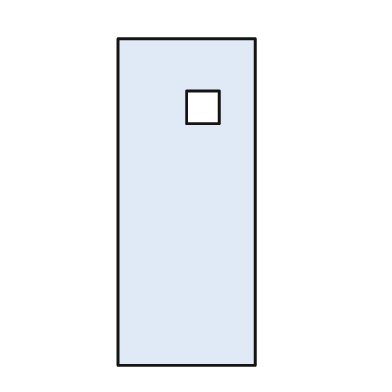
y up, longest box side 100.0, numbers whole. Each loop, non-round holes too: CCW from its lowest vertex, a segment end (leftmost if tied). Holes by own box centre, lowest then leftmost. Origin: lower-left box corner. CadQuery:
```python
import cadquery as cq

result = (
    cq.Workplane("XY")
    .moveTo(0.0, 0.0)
    .lineTo(42.0, 0.0)
    .lineTo(42.0, 100.0)
    .lineTo(0.0, 100.0)
    .close()
    .moveTo(21.0, 74.0)
    .lineTo(31.0, 74.0)
    .lineTo(31.0, 84.0)
    .lineTo(21.0, 84.0)
    .close()
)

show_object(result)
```